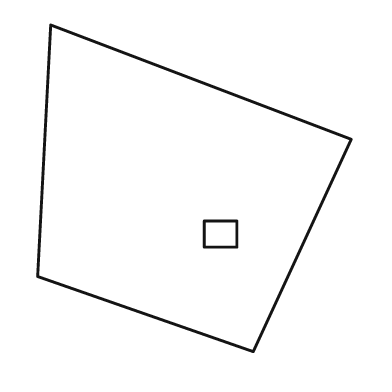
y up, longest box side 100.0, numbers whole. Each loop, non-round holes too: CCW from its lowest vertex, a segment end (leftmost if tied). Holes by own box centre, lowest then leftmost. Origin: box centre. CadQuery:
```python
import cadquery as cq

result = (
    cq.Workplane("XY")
    .moveTo(18.0, -50.0)
    .lineTo(48.0, 15.0)
    .lineTo(-44.0, 50.0)
    .lineTo(-48.0, -27.0)
    .close()
    .moveTo(3.0, -18.0)
    .lineTo(13.0, -18.0)
    .lineTo(13.0, -10.0)
    .lineTo(3.0, -10.0)
    .close()
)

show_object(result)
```